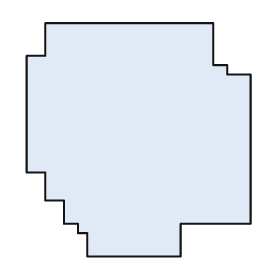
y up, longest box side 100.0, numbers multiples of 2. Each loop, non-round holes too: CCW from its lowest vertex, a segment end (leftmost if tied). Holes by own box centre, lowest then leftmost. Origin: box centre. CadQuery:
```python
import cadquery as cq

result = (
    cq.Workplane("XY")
    .moveTo(-22.0, -50.0)
    .lineTo(18.0, -50.0)
    .lineTo(18.0, -36.0)
    .lineTo(48.0, -36.0)
    .lineTo(48.0, 28.0)
    .lineTo(38.0, 28.0)
    .lineTo(38.0, 32.0)
    .lineTo(32.0, 32.0)
    .lineTo(32.0, 50.0)
    .lineTo(-40.0, 50.0)
    .lineTo(-40.0, 36.0)
    .lineTo(-48.0, 36.0)
    .lineTo(-48.0, -14.0)
    .lineTo(-40.0, -14.0)
    .lineTo(-40.0, -26.0)
    .lineTo(-32.0, -26.0)
    .lineTo(-32.0, -36.0)
    .lineTo(-26.0, -36.0)
    .lineTo(-26.0, -40.0)
    .lineTo(-22.0, -40.0)
    .close()
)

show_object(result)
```